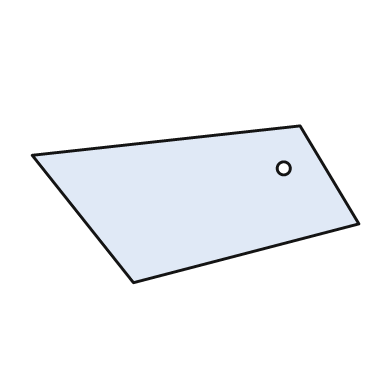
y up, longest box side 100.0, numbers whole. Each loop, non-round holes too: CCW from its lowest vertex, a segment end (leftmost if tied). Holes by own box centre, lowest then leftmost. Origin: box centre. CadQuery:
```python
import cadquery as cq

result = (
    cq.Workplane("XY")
    .moveTo(-19.0, -24.0)
    .lineTo(50.0, -6.0)
    .lineTo(32.0, 24.0)
    .lineTo(-50.0, 15.0)
    .close()
    .moveTo(27.0, 11.0)
    .circle(2.0)
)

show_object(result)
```